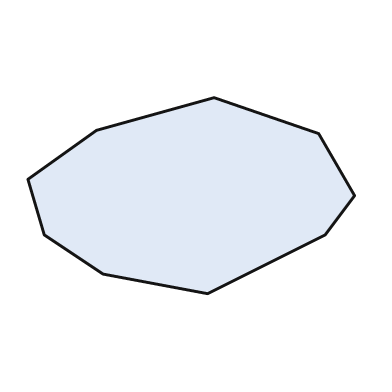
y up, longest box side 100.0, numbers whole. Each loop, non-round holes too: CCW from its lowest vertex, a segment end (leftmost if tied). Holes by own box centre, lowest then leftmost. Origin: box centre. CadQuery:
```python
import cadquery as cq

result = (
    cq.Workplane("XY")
    .moveTo(5.0, -30.0)
    .lineTo(41.0, -12.0)
    .lineTo(50.0, 0.0)
    .lineTo(39.0, 19.0)
    .lineTo(7.0, 30.0)
    .lineTo(-29.0, 20.0)
    .lineTo(-50.0, 5.0)
    .lineTo(-45.0, -12.0)
    .lineTo(-27.0, -24.0)
    .close()
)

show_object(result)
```